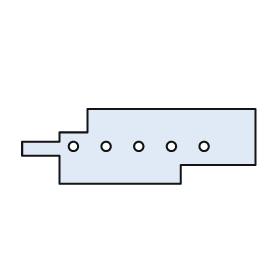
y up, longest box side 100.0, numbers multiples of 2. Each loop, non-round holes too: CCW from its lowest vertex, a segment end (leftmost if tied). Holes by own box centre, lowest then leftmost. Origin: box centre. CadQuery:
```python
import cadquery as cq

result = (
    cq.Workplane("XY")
    .moveTo(-34.0, -16.0)
    .lineTo(18.0, -16.0)
    .lineTo(18.0, -8.0)
    .lineTo(50.0, -8.0)
    .lineTo(50.0, 16.0)
    .lineTo(-22.0, 16.0)
    .lineTo(-22.0, 6.0)
    .lineTo(-34.0, 6.0)
    .lineTo(-34.0, 2.0)
    .lineTo(-50.0, 2.0)
    .lineTo(-50.0, -4.0)
    .lineTo(-34.0, -4.0)
    .close()
    .moveTo(-28.0, 0.0)
    .circle(2.0)
    .moveTo(-14.0, 0.0)
    .circle(2.0)
    .moveTo(0.0, 0.0)
    .circle(2.0)
    .moveTo(14.0, 0.0)
    .circle(2.0)
    .moveTo(28.0, 0.0)
    .circle(2.0)
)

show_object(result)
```